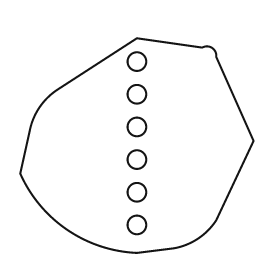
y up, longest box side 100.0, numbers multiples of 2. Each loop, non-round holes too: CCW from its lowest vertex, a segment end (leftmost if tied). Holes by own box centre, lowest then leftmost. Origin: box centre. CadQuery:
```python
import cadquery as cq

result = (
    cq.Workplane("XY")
    .moveTo(0.0, -46.0)
    .lineTo(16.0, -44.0)
    .threePointArc((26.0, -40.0), (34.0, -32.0))
    .lineTo(50.0, 2.0)
    .lineTo(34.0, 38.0)
    .threePointArc((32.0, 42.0), (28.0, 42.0))
    .lineTo(0.0, 46.0)
    .lineTo(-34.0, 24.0)
    .threePointArc((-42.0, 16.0), (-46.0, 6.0))
    .lineTo(-50.0, -12.0)
    .threePointArc((-30.0, -36.0), (0.0, -46.0))
    .close()
    .moveTo(0.0, -34.0)
    .circle(4.0)
    .moveTo(0.0, -20.0)
    .circle(4.0)
    .moveTo(0.0, -6.0)
    .circle(4.0)
    .moveTo(0.0, 8.0)
    .circle(4.0)
    .moveTo(0.0, 22.0)
    .circle(4.0)
    .moveTo(0.0, 36.0)
    .circle(4.0)
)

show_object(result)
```